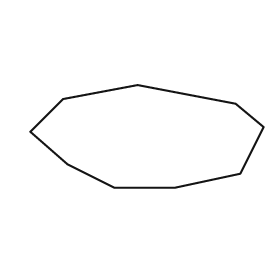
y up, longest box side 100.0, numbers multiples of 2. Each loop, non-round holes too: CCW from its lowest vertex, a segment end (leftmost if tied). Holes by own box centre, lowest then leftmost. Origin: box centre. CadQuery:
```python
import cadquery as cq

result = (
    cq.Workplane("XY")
    .moveTo(-14.0, -22.0)
    .lineTo(12.0, -22.0)
    .lineTo(40.0, -16.0)
    .lineTo(50.0, 4.0)
    .lineTo(38.0, 14.0)
    .lineTo(-4.0, 22.0)
    .lineTo(-36.0, 16.0)
    .lineTo(-50.0, 2.0)
    .lineTo(-34.0, -12.0)
    .close()
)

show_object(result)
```